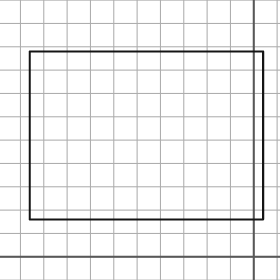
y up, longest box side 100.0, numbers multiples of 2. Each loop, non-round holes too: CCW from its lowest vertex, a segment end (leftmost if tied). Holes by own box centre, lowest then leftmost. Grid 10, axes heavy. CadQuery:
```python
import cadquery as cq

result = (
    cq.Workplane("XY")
    .moveTo(-96.0, 16.0)
    .lineTo(4.0, 16.0)
    .lineTo(4.0, 88.0)
    .lineTo(-96.0, 88.0)
    .close()
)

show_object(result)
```